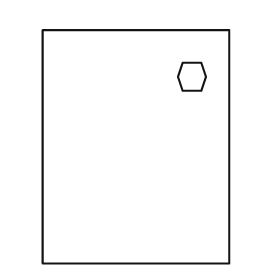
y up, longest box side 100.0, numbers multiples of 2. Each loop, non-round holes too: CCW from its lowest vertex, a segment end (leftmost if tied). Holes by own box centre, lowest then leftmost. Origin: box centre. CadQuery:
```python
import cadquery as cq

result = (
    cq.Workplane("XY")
    .moveTo(-40.0, -50.0)
    .lineTo(40.0, -50.0)
    .lineTo(40.0, 50.0)
    .lineTo(-40.0, 50.0)
    .close()
    .moveTo(20.0, 24.0)
    .lineTo(28.0, 24.0)
    .lineTo(30.0, 30.0)
    .lineTo(28.0, 36.0)
    .lineTo(20.0, 36.0)
    .lineTo(18.0, 30.0)
    .close()
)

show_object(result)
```